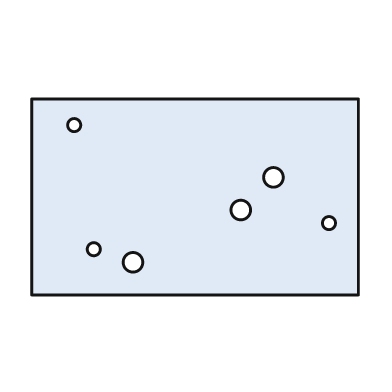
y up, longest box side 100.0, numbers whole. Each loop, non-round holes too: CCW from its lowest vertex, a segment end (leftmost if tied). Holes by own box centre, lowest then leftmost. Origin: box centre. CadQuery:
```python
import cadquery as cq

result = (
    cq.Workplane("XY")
    .moveTo(-50.0, -30.0)
    .lineTo(50.0, -30.0)
    .lineTo(50.0, 30.0)
    .lineTo(-50.0, 30.0)
    .close()
    .moveTo(-19.0, -20.0)
    .circle(3.0)
    .moveTo(-31.0, -16.0)
    .circle(2.0)
    .moveTo(41.0, -8.0)
    .circle(2.0)
    .moveTo(14.0, -4.0)
    .circle(3.0)
    .moveTo(24.0, 6.0)
    .circle(3.0)
    .moveTo(-37.0, 22.0)
    .circle(2.0)
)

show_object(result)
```